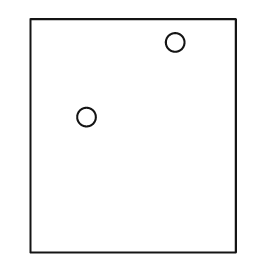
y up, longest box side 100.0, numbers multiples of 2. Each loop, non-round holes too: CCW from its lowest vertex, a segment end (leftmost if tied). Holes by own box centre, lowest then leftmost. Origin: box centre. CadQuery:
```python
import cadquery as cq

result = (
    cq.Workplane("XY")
    .moveTo(-44.0, -50.0)
    .lineTo(44.0, -50.0)
    .lineTo(44.0, 50.0)
    .lineTo(-44.0, 50.0)
    .close()
    .moveTo(-20.0, 8.0)
    .circle(4.0)
    .moveTo(18.0, 40.0)
    .circle(4.0)
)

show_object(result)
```